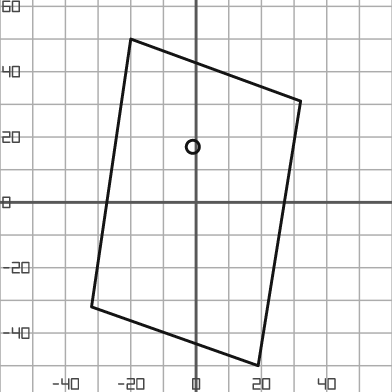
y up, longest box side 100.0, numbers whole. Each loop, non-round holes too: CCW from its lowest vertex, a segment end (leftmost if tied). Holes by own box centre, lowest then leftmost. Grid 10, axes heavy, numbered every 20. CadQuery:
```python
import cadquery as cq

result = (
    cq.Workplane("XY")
    .moveTo(19.0, -50.0)
    .lineTo(32.0, 31.0)
    .lineTo(-20.0, 50.0)
    .lineTo(-32.0, -32.0)
    .close()
    .moveTo(-1.0, 17.0)
    .circle(2.0)
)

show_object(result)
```